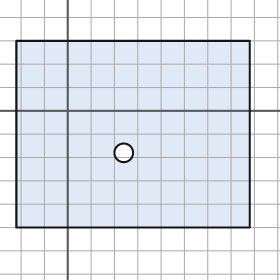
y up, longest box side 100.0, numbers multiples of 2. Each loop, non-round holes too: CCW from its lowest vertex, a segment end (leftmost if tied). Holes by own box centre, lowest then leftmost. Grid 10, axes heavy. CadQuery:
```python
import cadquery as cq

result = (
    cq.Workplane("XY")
    .moveTo(-22.0, -50.0)
    .lineTo(78.0, -50.0)
    .lineTo(78.0, 30.0)
    .lineTo(-22.0, 30.0)
    .close()
    .moveTo(24.0, -18.0)
    .circle(4.0)
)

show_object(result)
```